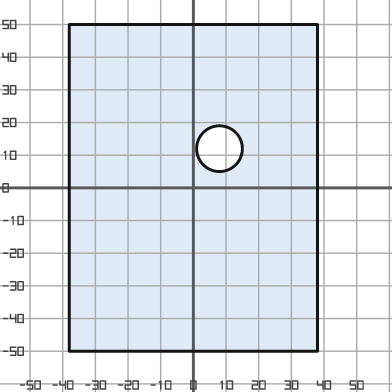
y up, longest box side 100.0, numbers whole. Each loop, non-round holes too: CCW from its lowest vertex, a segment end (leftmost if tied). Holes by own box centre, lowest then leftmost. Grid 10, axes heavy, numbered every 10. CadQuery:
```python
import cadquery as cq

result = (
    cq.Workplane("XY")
    .moveTo(-38.0, -50.0)
    .lineTo(38.0, -50.0)
    .lineTo(38.0, 50.0)
    .lineTo(-38.0, 50.0)
    .close()
    .moveTo(8.0, 12.0)
    .circle(7.0)
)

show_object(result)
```